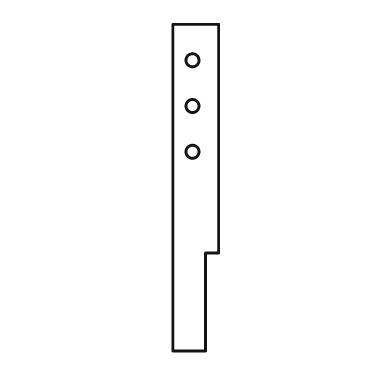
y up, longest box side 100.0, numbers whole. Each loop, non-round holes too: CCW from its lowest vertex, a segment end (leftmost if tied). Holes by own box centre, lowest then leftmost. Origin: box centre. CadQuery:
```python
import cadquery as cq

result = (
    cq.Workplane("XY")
    .moveTo(-7.0, -50.0)
    .lineTo(3.0, -50.0)
    .lineTo(3.0, -20.0)
    .lineTo(7.0, -20.0)
    .lineTo(7.0, 50.0)
    .lineTo(-7.0, 50.0)
    .close()
    .moveTo(-1.0, 11.0)
    .circle(2.0)
    .moveTo(-1.0, 25.0)
    .circle(2.0)
    .moveTo(-1.0, 39.0)
    .circle(2.0)
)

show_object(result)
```